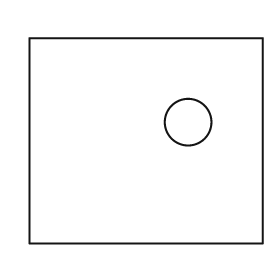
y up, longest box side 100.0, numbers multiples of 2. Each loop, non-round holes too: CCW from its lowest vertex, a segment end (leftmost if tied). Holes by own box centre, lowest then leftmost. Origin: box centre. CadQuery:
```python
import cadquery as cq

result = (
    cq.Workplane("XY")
    .moveTo(-50.0, -44.0)
    .lineTo(50.0, -44.0)
    .lineTo(50.0, 44.0)
    .lineTo(-50.0, 44.0)
    .close()
    .moveTo(18.0, 8.0)
    .circle(10.0)
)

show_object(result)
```